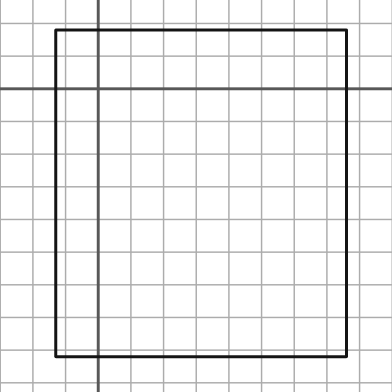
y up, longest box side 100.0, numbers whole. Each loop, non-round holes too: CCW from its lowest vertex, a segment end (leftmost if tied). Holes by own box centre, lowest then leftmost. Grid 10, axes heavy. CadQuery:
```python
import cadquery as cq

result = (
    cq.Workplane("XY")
    .moveTo(-13.0, -82.0)
    .lineTo(76.0, -82.0)
    .lineTo(76.0, 18.0)
    .lineTo(-13.0, 18.0)
    .close()
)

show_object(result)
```